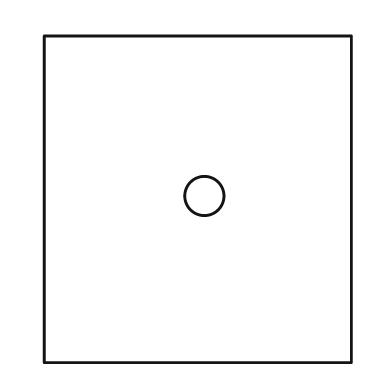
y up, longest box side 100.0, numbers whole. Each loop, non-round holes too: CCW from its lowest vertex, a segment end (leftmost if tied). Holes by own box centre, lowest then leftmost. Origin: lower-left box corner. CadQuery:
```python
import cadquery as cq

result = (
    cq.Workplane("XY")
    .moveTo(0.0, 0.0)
    .lineTo(94.0, 0.0)
    .lineTo(94.0, 100.0)
    .lineTo(0.0, 100.0)
    .close()
    .moveTo(49.0, 51.0)
    .circle(6.0)
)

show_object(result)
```